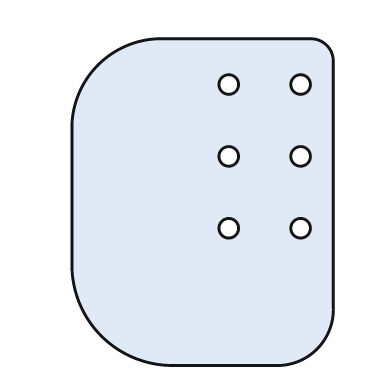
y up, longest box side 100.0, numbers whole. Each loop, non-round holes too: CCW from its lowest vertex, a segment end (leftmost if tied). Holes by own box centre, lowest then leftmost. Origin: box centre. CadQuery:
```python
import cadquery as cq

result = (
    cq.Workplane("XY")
    .moveTo(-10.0, -50.0)
    .lineTo(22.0, -50.0)
    .threePointArc((35.0, -45.0), (40.0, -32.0))
    .lineTo(40.0, 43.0)
    .threePointArc((38.0, 48.0), (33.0, 50.0))
    .lineTo(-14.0, 50.0)
    .threePointArc((-32.0, 42.0), (-40.0, 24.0))
    .lineTo(-40.0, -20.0)
    .threePointArc((-31.0, -41.0), (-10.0, -50.0))
    .close()
    .moveTo(8.0, -8.0)
    .circle(3.0)
    .moveTo(30.0, -8.0)
    .circle(3.0)
    .moveTo(8.0, 14.0)
    .circle(3.0)
    .moveTo(30.0, 14.0)
    .circle(3.0)
    .moveTo(8.0, 36.0)
    .circle(3.0)
    .moveTo(30.0, 36.0)
    .circle(3.0)
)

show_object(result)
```